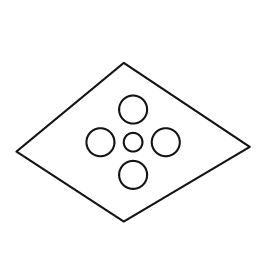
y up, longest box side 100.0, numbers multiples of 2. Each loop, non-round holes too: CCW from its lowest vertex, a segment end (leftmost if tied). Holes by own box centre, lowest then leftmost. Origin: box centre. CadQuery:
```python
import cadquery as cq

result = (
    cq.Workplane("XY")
    .moveTo(-4.0, -34.0)
    .lineTo(50.0, -2.0)
    .lineTo(-4.0, 34.0)
    .lineTo(-50.0, -4.0)
    .close()
    .moveTo(0.0, -14.0)
    .circle(6.0)
    .moveTo(-14.0, 0.0)
    .circle(6.0)
    .moveTo(0.0, 0.0)
    .circle(4.0)
    .moveTo(14.0, 0.0)
    .circle(6.0)
    .moveTo(0.0, 14.0)
    .circle(6.0)
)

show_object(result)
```